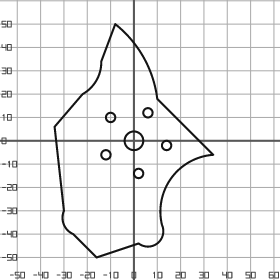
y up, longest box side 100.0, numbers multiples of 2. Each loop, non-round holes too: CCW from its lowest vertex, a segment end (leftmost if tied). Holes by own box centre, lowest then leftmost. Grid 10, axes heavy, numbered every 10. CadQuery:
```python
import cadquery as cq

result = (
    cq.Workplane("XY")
    .moveTo(-16.0, -50.0)
    .lineTo(2.0, -44.0)
    .threePointArc((10.0, -44.0), (12.0, -36.0))
    .threePointArc((16.0, -16.0), (34.0, -6.0))
    .lineTo(10.0, 18.0)
    .threePointArc((4.0, 36.0), (-8.0, 50.0))
    .lineTo(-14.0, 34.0)
    .threePointArc((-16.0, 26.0), (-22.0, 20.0))
    .lineTo(-34.0, 6.0)
    .lineTo(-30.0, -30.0)
    .threePointArc((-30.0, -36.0), (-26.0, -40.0))
    .close()
    .moveTo(2.0, -14.0)
    .circle(2.0)
    .moveTo(-12.0, -6.0)
    .circle(2.0)
    .moveTo(14.0, -2.0)
    .circle(2.0)
    .moveTo(0.0, 0.0)
    .circle(4.0)
    .moveTo(-10.0, 10.0)
    .circle(2.0)
    .moveTo(6.0, 12.0)
    .circle(2.0)
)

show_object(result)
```